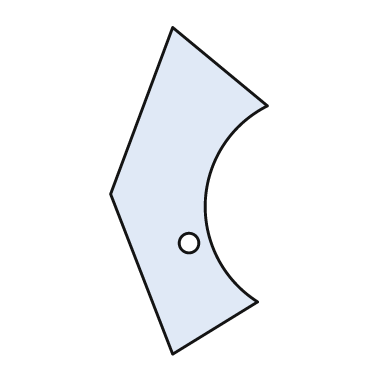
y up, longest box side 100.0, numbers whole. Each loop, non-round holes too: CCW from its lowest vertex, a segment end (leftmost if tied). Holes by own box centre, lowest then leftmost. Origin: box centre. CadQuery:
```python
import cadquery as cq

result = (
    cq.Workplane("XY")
    .moveTo(-5.0, -50.0)
    .lineTo(21.0, -34.0)
    .threePointArc((5.0, -3.0), (24.0, 26.0))
    .lineTo(-5.0, 50.0)
    .lineTo(-24.0, -1.0)
    .close()
    .moveTo(0.0, -16.0)
    .circle(3.0)
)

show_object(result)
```